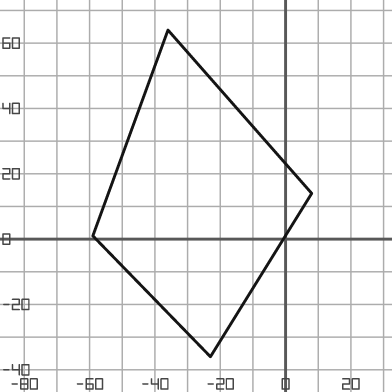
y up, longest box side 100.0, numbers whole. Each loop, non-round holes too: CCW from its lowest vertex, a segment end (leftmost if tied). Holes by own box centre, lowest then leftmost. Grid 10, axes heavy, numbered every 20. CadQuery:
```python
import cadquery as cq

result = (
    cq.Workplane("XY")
    .moveTo(-23.0, -36.0)
    .lineTo(8.0, 14.0)
    .lineTo(-36.0, 64.0)
    .lineTo(-59.0, 1.0)
    .close()
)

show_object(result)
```